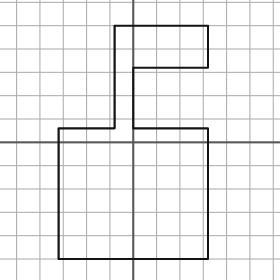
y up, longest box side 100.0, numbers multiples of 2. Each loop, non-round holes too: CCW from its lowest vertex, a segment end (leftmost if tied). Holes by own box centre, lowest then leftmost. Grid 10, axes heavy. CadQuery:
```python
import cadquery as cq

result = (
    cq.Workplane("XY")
    .moveTo(-32.0, -50.0)
    .lineTo(32.0, -50.0)
    .lineTo(32.0, 6.0)
    .lineTo(0.0, 6.0)
    .lineTo(0.0, 32.0)
    .lineTo(32.0, 32.0)
    .lineTo(32.0, 50.0)
    .lineTo(-8.0, 50.0)
    .lineTo(-8.0, 6.0)
    .lineTo(-32.0, 6.0)
    .close()
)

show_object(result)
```